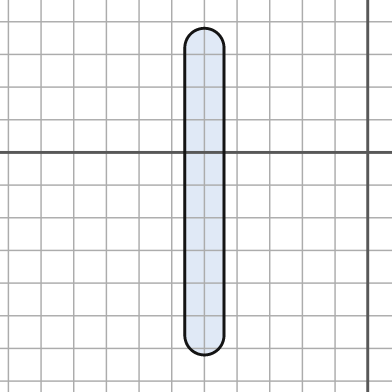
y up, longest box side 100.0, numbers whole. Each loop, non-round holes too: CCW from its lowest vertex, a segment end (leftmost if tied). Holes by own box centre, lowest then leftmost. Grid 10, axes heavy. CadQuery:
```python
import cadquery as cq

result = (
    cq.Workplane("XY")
    .moveTo(-56.0, -56.0)
    .threePointArc((-50.0, -62.0), (-44.0, -56.0))
    .lineTo(-44.0, 32.0)
    .threePointArc((-50.0, 38.0), (-56.0, 32.0))
    .close()
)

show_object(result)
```